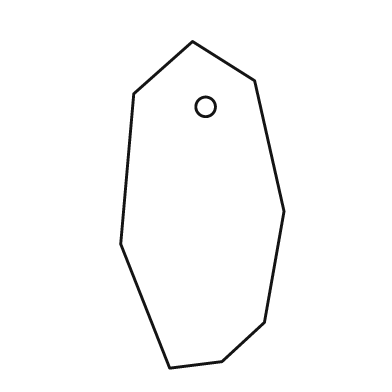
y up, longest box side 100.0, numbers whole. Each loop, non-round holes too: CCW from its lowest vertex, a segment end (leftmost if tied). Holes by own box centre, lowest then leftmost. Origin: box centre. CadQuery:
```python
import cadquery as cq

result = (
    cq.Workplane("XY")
    .moveTo(-10.0, -50.0)
    .lineTo(6.0, -48.0)
    .lineTo(19.0, -36.0)
    .lineTo(25.0, -2.0)
    .lineTo(16.0, 38.0)
    .lineTo(-3.0, 50.0)
    .lineTo(-21.0, 34.0)
    .lineTo(-25.0, -12.0)
    .close()
    .moveTo(1.0, 30.0)
    .circle(3.0)
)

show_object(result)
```